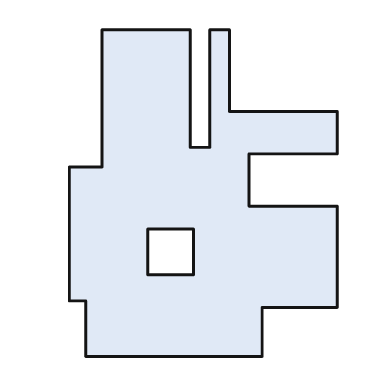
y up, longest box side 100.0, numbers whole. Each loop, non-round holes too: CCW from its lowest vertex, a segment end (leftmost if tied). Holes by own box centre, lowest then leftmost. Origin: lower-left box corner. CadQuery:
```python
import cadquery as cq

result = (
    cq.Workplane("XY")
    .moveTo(5.0, 0.0)
    .lineTo(59.0, 0.0)
    .lineTo(59.0, 15.0)
    .lineTo(82.0, 15.0)
    .lineTo(82.0, 46.0)
    .lineTo(55.0, 46.0)
    .lineTo(55.0, 62.0)
    .lineTo(82.0, 62.0)
    .lineTo(82.0, 75.0)
    .lineTo(49.0, 75.0)
    .lineTo(49.0, 100.0)
    .lineTo(43.0, 100.0)
    .lineTo(43.0, 64.0)
    .lineTo(37.0, 64.0)
    .lineTo(37.0, 100.0)
    .lineTo(10.0, 100.0)
    .lineTo(10.0, 58.0)
    .lineTo(0.0, 58.0)
    .lineTo(0.0, 17.0)
    .lineTo(5.0, 17.0)
    .close()
    .moveTo(24.0, 25.0)
    .lineTo(38.0, 25.0)
    .lineTo(38.0, 39.0)
    .lineTo(24.0, 39.0)
    .close()
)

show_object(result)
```